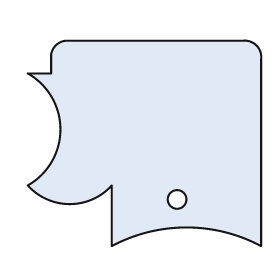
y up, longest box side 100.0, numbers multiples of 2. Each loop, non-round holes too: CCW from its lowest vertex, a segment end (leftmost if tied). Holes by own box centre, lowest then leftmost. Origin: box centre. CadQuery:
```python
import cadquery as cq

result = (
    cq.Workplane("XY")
    .moveTo(-14.0, -44.0)
    .threePointArc((18.0, -36.0), (50.0, -44.0))
    .lineTo(50.0, 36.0)
    .threePointArc((48.0, 42.0), (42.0, 44.0))
    .lineTo(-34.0, 44.0)
    .threePointArc((-38.0, 42.0), (-40.0, 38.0))
    .lineTo(-40.0, 30.0)
    .lineTo(-50.0, 30.0)
    .threePointArc((-36.0, 6.0), (-50.0, -18.0))
    .threePointArc((-32.0, -26.0), (-14.0, -18.0))
    .close()
    .moveTo(14.0, -24.0)
    .circle(4.0)
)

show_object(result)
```